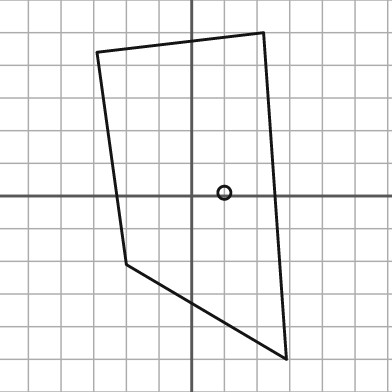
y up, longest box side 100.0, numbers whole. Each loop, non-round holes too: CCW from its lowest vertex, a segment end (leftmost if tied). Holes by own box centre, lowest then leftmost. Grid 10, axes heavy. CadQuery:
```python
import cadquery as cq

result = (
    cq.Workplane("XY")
    .moveTo(29.0, -50.0)
    .lineTo(22.0, 50.0)
    .lineTo(-29.0, 44.0)
    .lineTo(-20.0, -21.0)
    .close()
    .moveTo(10.0, 1.0)
    .circle(2.0)
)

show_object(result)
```